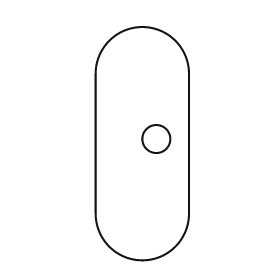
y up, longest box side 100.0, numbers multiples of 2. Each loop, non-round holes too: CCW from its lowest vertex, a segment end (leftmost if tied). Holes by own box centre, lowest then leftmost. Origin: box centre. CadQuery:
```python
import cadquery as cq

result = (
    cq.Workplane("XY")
    .moveTo(-20.0, -30.0)
    .threePointArc((0.0, -50.0), (20.0, -30.0))
    .lineTo(20.0, 30.0)
    .threePointArc((0.0, 50.0), (-20.0, 30.0))
    .close()
    .moveTo(6.0, 2.0)
    .circle(6.0)
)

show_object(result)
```